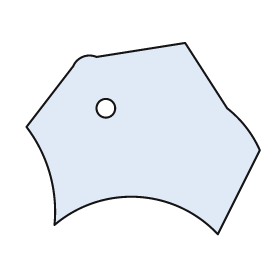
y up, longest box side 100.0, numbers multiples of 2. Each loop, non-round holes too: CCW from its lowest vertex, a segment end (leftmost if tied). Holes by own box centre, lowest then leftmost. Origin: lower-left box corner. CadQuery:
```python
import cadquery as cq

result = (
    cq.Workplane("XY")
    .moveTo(82.0, 0.0)
    .lineTo(100.0, 36.0)
    .threePointArc((94.0, 46.0), (86.0, 54.0))
    .lineTo(68.0, 82.0)
    .lineTo(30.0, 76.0)
    .threePointArc((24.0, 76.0), (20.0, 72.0))
    .lineTo(0.0, 46.0)
    .threePointArc((10.0, 26.0), (12.0, 4.0))
    .threePointArc((48.0, 16.0), (82.0, 0.0))
    .close()
    .moveTo(34.0, 54.0)
    .circle(4.0)
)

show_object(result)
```